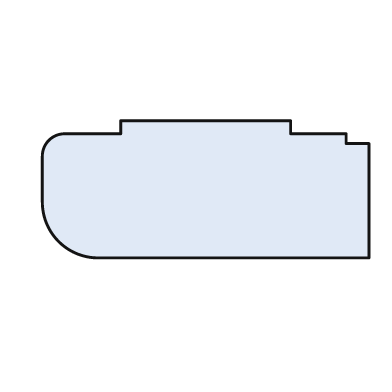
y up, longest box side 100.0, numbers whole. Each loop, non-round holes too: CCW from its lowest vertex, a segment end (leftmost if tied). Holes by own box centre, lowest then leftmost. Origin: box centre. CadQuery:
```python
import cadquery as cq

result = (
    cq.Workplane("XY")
    .moveTo(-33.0, -21.0)
    .lineTo(50.0, -21.0)
    .lineTo(50.0, 14.0)
    .lineTo(43.0, 14.0)
    .lineTo(43.0, 17.0)
    .lineTo(26.0, 17.0)
    .lineTo(26.0, 21.0)
    .lineTo(-26.0, 21.0)
    .lineTo(-26.0, 17.0)
    .lineTo(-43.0, 17.0)
    .threePointArc((-48.0, 15.0), (-50.0, 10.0))
    .lineTo(-50.0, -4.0)
    .threePointArc((-45.0, -16.0), (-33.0, -21.0))
    .close()
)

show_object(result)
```